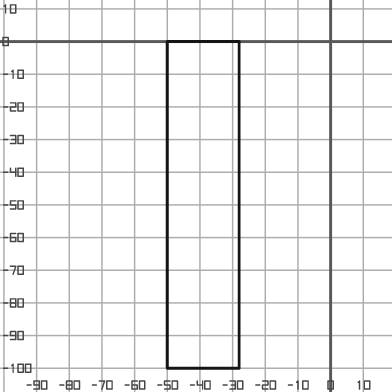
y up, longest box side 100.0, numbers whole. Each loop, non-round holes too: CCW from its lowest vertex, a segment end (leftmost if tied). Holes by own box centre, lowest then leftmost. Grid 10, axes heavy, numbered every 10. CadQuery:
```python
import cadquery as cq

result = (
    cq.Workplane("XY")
    .moveTo(-50.0, -100.0)
    .lineTo(-28.0, -100.0)
    .lineTo(-28.0, 0.0)
    .lineTo(-50.0, 0.0)
    .close()
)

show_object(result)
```